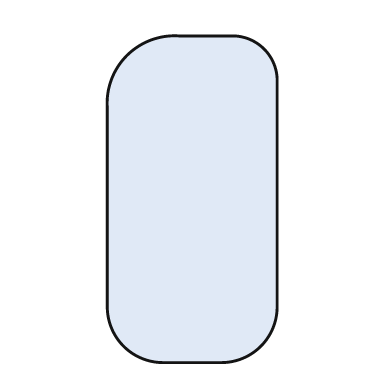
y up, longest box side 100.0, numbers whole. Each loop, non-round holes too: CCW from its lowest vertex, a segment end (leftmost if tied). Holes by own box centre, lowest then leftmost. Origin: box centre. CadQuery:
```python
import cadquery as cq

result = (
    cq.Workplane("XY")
    .moveTo(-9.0, -50.0)
    .lineTo(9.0, -50.0)
    .threePointArc((21.0, -45.0), (26.0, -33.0))
    .lineTo(26.0, 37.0)
    .threePointArc((22.0, 46.0), (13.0, 50.0))
    .lineTo(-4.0, 50.0)
    .threePointArc((-20.0, 44.0), (-26.0, 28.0))
    .lineTo(-26.0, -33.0)
    .threePointArc((-21.0, -45.0), (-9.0, -50.0))
    .close()
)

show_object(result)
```